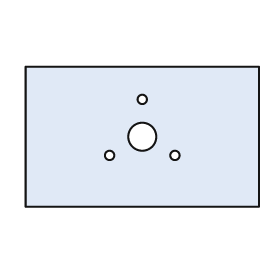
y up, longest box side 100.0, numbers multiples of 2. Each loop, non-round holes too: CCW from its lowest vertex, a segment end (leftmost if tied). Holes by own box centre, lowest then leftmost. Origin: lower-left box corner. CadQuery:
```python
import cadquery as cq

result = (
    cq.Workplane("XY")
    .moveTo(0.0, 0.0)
    .lineTo(100.0, 0.0)
    .lineTo(100.0, 60.0)
    .lineTo(0.0, 60.0)
    .close()
    .moveTo(36.0, 22.0)
    .circle(2.0)
    .moveTo(64.0, 22.0)
    .circle(2.0)
    .moveTo(50.0, 30.0)
    .circle(6.0)
    .moveTo(50.0, 46.0)
    .circle(2.0)
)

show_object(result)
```